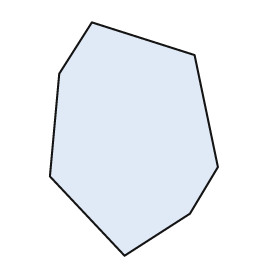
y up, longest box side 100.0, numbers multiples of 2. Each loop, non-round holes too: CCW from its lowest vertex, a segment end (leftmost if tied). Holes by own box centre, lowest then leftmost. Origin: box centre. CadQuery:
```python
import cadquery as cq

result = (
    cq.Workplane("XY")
    .moveTo(-4.0, -50.0)
    .lineTo(24.0, -32.0)
    .lineTo(36.0, -12.0)
    .lineTo(26.0, 36.0)
    .lineTo(-18.0, 50.0)
    .lineTo(-32.0, 28.0)
    .lineTo(-36.0, -16.0)
    .close()
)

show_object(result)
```